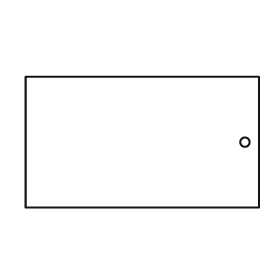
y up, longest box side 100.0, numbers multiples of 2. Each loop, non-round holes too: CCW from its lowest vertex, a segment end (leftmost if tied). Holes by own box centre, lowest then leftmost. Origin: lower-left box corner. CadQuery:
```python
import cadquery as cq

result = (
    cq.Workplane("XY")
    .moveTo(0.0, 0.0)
    .lineTo(100.0, 0.0)
    .lineTo(100.0, 56.0)
    .lineTo(0.0, 56.0)
    .close()
    .moveTo(94.0, 28.0)
    .circle(2.0)
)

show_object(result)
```